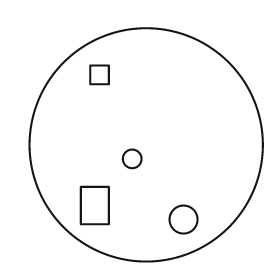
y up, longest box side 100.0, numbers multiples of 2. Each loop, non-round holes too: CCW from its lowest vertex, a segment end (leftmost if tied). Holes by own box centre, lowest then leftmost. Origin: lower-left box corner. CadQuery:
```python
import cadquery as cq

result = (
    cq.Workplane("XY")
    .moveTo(50.0, 50.0)
    .circle(50.0)
    .moveTo(66.0, 18.0)
    .circle(6.0)
    .moveTo(22.0, 16.0)
    .lineTo(34.0, 16.0)
    .lineTo(34.0, 32.0)
    .lineTo(22.0, 32.0)
    .close()
    .moveTo(44.0, 44.0)
    .circle(4.0)
    .moveTo(26.0, 76.0)
    .lineTo(34.0, 76.0)
    .lineTo(34.0, 84.0)
    .lineTo(26.0, 84.0)
    .close()
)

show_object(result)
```